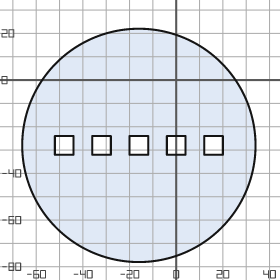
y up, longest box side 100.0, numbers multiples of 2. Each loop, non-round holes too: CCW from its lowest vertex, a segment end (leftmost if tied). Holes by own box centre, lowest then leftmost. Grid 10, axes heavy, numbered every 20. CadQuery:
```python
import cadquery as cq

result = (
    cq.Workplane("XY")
    .moveTo(-16.0, -28.0)
    .circle(50.0)
    .moveTo(-52.0, -32.0)
    .lineTo(-44.0, -32.0)
    .lineTo(-44.0, -24.0)
    .lineTo(-52.0, -24.0)
    .close()
    .moveTo(-36.0, -32.0)
    .lineTo(-28.0, -32.0)
    .lineTo(-28.0, -24.0)
    .lineTo(-36.0, -24.0)
    .close()
    .moveTo(-20.0, -32.0)
    .lineTo(-12.0, -32.0)
    .lineTo(-12.0, -24.0)
    .lineTo(-20.0, -24.0)
    .close()
    .moveTo(-4.0, -32.0)
    .lineTo(4.0, -32.0)
    .lineTo(4.0, -24.0)
    .lineTo(-4.0, -24.0)
    .close()
    .moveTo(12.0, -32.0)
    .lineTo(20.0, -32.0)
    .lineTo(20.0, -24.0)
    .lineTo(12.0, -24.0)
    .close()
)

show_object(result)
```